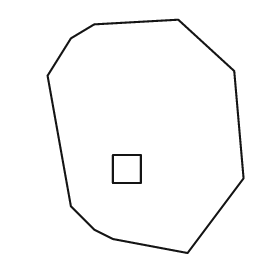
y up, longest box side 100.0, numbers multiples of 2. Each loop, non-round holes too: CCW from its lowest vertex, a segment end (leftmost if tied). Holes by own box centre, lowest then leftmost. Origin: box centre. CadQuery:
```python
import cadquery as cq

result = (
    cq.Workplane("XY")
    .moveTo(18.0, -50.0)
    .lineTo(42.0, -18.0)
    .lineTo(38.0, 28.0)
    .lineTo(14.0, 50.0)
    .lineTo(-22.0, 48.0)
    .lineTo(-32.0, 42.0)
    .lineTo(-42.0, 26.0)
    .lineTo(-32.0, -30.0)
    .lineTo(-22.0, -40.0)
    .lineTo(-14.0, -44.0)
    .close()
    .moveTo(-14.0, -20.0)
    .lineTo(-2.0, -20.0)
    .lineTo(-2.0, -8.0)
    .lineTo(-14.0, -8.0)
    .close()
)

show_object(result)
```